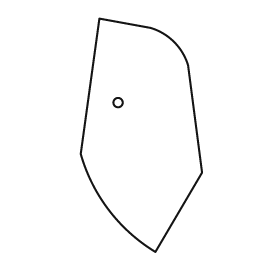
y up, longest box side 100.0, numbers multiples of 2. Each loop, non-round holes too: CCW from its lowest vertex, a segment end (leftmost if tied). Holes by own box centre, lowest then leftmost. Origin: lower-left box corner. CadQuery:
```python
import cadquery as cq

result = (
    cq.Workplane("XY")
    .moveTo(32.0, 0.0)
    .lineTo(52.0, 34.0)
    .lineTo(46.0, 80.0)
    .threePointArc((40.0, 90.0), (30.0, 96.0))
    .lineTo(8.0, 100.0)
    .lineTo(0.0, 42.0)
    .threePointArc((12.0, 18.0), (32.0, 0.0))
    .close()
    .moveTo(16.0, 64.0)
    .circle(2.0)
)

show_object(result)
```